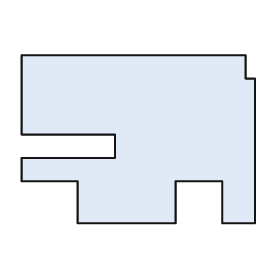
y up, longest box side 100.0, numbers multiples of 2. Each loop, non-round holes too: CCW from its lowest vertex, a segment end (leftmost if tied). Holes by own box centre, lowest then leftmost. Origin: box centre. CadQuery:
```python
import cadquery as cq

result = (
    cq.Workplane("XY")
    .moveTo(-26.0, -36.0)
    .lineTo(16.0, -36.0)
    .lineTo(16.0, -18.0)
    .lineTo(36.0, -18.0)
    .lineTo(36.0, -36.0)
    .lineTo(50.0, -36.0)
    .lineTo(50.0, 26.0)
    .lineTo(46.0, 26.0)
    .lineTo(46.0, 36.0)
    .lineTo(-50.0, 36.0)
    .lineTo(-50.0, 2.0)
    .lineTo(-10.0, 2.0)
    .lineTo(-10.0, -8.0)
    .lineTo(-50.0, -8.0)
    .lineTo(-50.0, -18.0)
    .lineTo(-26.0, -18.0)
    .close()
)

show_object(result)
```